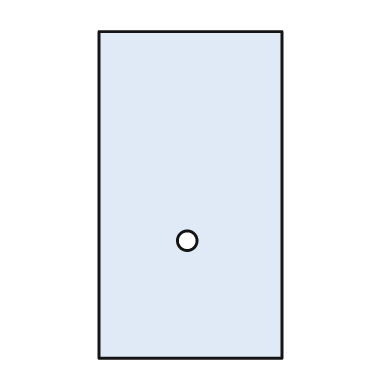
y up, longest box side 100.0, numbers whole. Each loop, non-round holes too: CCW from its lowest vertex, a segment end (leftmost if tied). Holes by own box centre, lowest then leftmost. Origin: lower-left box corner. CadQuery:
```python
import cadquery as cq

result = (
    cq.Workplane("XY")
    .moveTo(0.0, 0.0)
    .lineTo(56.0, 0.0)
    .lineTo(56.0, 100.0)
    .lineTo(0.0, 100.0)
    .close()
    .moveTo(27.0, 36.0)
    .circle(3.0)
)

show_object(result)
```